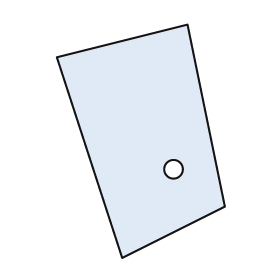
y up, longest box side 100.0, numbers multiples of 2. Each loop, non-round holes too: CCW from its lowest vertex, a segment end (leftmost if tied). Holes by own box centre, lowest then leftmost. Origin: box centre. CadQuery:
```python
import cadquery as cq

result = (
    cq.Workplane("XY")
    .moveTo(-8.0, -50.0)
    .lineTo(36.0, -28.0)
    .lineTo(20.0, 50.0)
    .lineTo(-36.0, 36.0)
    .close()
    .moveTo(14.0, -12.0)
    .circle(4.0)
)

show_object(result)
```